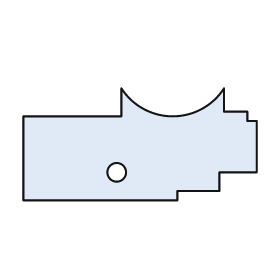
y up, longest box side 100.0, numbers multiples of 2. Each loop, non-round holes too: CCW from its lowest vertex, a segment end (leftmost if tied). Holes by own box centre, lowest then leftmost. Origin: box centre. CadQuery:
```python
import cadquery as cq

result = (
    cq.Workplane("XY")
    .moveTo(-50.0, -24.0)
    .lineTo(16.0, -24.0)
    .lineTo(16.0, -20.0)
    .lineTo(34.0, -20.0)
    .lineTo(34.0, -12.0)
    .lineTo(50.0, -12.0)
    .lineTo(50.0, 10.0)
    .lineTo(46.0, 10.0)
    .lineTo(46.0, 14.0)
    .lineTo(36.0, 14.0)
    .lineTo(36.0, 24.0)
    .threePointArc((14.0, 12.0), (-8.0, 24.0))
    .lineTo(-8.0, 12.0)
    .lineTo(-50.0, 12.0)
    .close()
    .moveTo(-10.0, -12.0)
    .circle(4.0)
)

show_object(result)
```